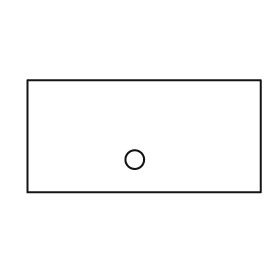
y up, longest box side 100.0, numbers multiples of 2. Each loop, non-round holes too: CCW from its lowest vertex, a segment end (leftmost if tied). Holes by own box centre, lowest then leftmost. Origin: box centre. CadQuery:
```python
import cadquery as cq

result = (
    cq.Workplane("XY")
    .moveTo(-50.0, -24.0)
    .lineTo(50.0, -24.0)
    .lineTo(50.0, 24.0)
    .lineTo(-50.0, 24.0)
    .close()
    .moveTo(-4.0, -10.0)
    .circle(4.0)
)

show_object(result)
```